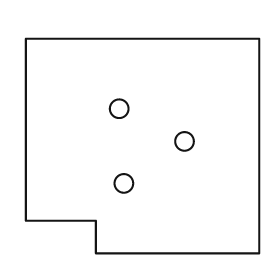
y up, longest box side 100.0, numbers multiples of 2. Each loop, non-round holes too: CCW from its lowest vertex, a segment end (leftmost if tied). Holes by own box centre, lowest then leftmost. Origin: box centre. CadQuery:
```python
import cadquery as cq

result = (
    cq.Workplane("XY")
    .moveTo(-20.0, -46.0)
    .lineTo(50.0, -46.0)
    .lineTo(50.0, 46.0)
    .lineTo(-50.0, 46.0)
    .lineTo(-50.0, -32.0)
    .lineTo(-20.0, -32.0)
    .close()
    .moveTo(-8.0, -16.0)
    .circle(4.0)
    .moveTo(18.0, 2.0)
    .circle(4.0)
    .moveTo(-10.0, 16.0)
    .circle(4.0)
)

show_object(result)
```